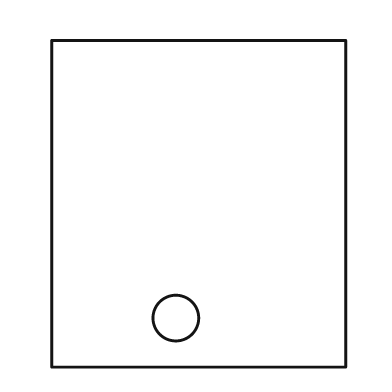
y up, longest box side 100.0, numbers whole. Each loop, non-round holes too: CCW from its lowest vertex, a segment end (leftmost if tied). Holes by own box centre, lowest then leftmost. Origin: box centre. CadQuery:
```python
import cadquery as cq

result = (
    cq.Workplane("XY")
    .moveTo(-45.0, -50.0)
    .lineTo(45.0, -50.0)
    .lineTo(45.0, 50.0)
    .lineTo(-45.0, 50.0)
    .close()
    .moveTo(-7.0, -35.0)
    .circle(7.0)
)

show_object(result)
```